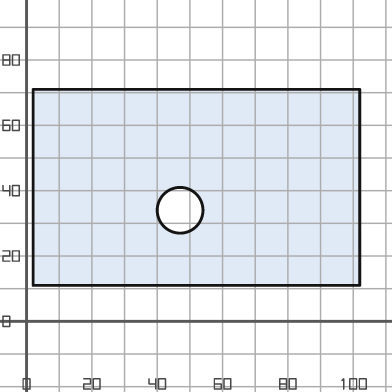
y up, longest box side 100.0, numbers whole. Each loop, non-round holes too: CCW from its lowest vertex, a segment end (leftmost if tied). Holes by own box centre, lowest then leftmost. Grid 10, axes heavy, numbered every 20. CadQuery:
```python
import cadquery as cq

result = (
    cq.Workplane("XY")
    .moveTo(2.0, 11.0)
    .lineTo(102.0, 11.0)
    .lineTo(102.0, 71.0)
    .lineTo(2.0, 71.0)
    .close()
    .moveTo(47.0, 34.0)
    .circle(7.0)
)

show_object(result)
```